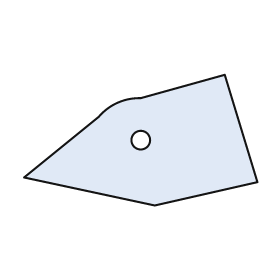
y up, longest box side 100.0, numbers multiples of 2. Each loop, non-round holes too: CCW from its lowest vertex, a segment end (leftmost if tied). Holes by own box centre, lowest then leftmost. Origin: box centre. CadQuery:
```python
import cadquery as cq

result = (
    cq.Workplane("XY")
    .moveTo(6.0, -28.0)
    .lineTo(50.0, -18.0)
    .lineTo(36.0, 28.0)
    .lineTo(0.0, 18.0)
    .threePointArc((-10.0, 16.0), (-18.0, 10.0))
    .lineTo(-50.0, -16.0)
    .close()
    .moveTo(0.0, 0.0)
    .circle(4.0)
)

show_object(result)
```